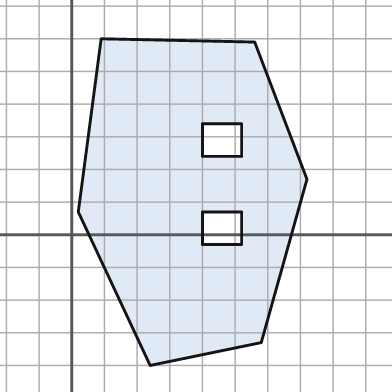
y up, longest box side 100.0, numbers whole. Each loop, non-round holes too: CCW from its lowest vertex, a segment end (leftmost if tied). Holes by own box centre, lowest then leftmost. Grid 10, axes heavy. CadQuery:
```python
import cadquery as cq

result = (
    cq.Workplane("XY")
    .moveTo(24.0, -40.0)
    .lineTo(58.0, -33.0)
    .lineTo(72.0, 17.0)
    .lineTo(56.0, 59.0)
    .lineTo(9.0, 60.0)
    .lineTo(2.0, 7.0)
    .close()
    .moveTo(40.0, -3.0)
    .lineTo(52.0, -3.0)
    .lineTo(52.0, 7.0)
    .lineTo(40.0, 7.0)
    .close()
    .moveTo(40.0, 24.0)
    .lineTo(52.0, 24.0)
    .lineTo(52.0, 34.0)
    .lineTo(40.0, 34.0)
    .close()
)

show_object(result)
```